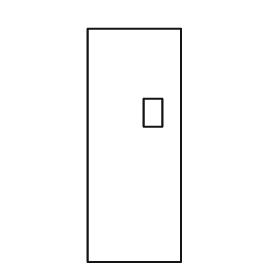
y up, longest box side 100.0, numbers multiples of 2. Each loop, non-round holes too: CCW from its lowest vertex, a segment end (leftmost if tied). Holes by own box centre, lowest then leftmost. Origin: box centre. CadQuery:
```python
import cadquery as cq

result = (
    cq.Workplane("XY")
    .moveTo(-20.0, -50.0)
    .lineTo(20.0, -50.0)
    .lineTo(20.0, 50.0)
    .lineTo(-20.0, 50.0)
    .close()
    .moveTo(4.0, 8.0)
    .lineTo(12.0, 8.0)
    .lineTo(12.0, 20.0)
    .lineTo(4.0, 20.0)
    .close()
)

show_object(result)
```